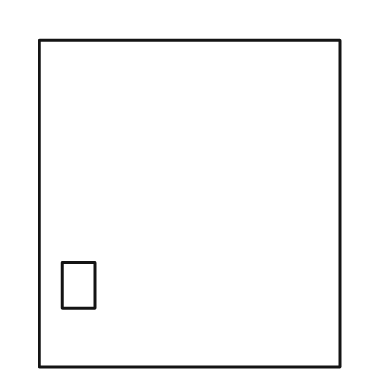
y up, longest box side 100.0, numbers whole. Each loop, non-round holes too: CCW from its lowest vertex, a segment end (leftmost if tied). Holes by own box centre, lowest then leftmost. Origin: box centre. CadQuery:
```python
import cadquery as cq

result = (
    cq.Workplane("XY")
    .moveTo(-46.0, -50.0)
    .lineTo(46.0, -50.0)
    .lineTo(46.0, 50.0)
    .lineTo(-46.0, 50.0)
    .close()
    .moveTo(-39.0, -32.0)
    .lineTo(-29.0, -32.0)
    .lineTo(-29.0, -18.0)
    .lineTo(-39.0, -18.0)
    .close()
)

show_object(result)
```